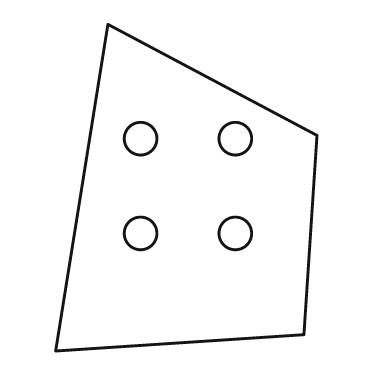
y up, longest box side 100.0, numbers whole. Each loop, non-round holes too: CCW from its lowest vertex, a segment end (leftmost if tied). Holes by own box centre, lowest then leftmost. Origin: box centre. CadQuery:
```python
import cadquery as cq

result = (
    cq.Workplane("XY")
    .moveTo(-40.0, -50.0)
    .lineTo(36.0, -45.0)
    .lineTo(40.0, 16.0)
    .lineTo(-24.0, 50.0)
    .close()
    .moveTo(-14.0, -14.0)
    .circle(5.0)
    .moveTo(15.0, -14.0)
    .circle(5.0)
    .moveTo(-14.0, 15.0)
    .circle(5.0)
    .moveTo(15.0, 15.0)
    .circle(5.0)
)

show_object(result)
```